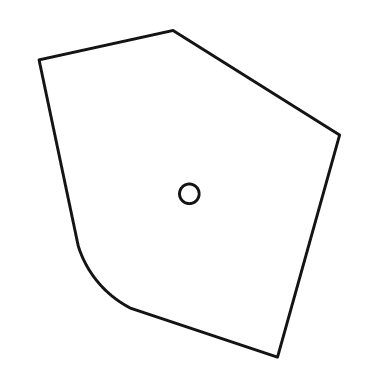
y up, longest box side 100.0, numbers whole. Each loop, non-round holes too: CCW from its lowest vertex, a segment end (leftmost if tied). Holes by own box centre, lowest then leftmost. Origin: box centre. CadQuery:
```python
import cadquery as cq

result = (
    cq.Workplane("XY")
    .moveTo(27.0, -50.0)
    .lineTo(46.0, 18.0)
    .lineTo(-5.0, 50.0)
    .lineTo(-46.0, 41.0)
    .lineTo(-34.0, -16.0)
    .threePointArc((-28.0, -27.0), (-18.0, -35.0))
    .close()
    .moveTo(0.0, 0.0)
    .circle(3.0)
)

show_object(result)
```